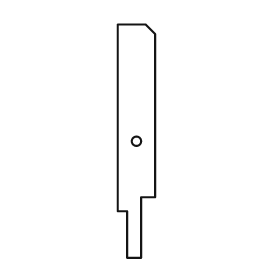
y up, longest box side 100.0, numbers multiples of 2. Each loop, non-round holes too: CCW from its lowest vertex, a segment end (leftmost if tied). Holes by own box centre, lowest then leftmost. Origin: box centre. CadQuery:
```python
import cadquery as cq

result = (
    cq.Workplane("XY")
    .moveTo(-4.0, -50.0)
    .lineTo(2.0, -50.0)
    .lineTo(2.0, -24.0)
    .lineTo(8.0, -24.0)
    .lineTo(8.0, 46.0)
    .lineTo(4.0, 50.0)
    .lineTo(-8.0, 50.0)
    .lineTo(-8.0, -30.0)
    .lineTo(-4.0, -30.0)
    .close()
    .moveTo(0.0, 0.0)
    .circle(2.0)
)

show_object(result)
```